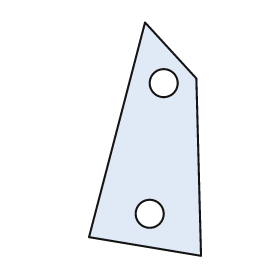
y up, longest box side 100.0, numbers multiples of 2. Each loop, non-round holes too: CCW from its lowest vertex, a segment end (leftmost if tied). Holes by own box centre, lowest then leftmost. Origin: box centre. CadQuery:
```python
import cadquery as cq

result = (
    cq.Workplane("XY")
    .moveTo(24.0, -50.0)
    .lineTo(22.0, 26.0)
    .lineTo(0.0, 50.0)
    .lineTo(-24.0, -42.0)
    .close()
    .moveTo(2.0, -32.0)
    .circle(6.0)
    .moveTo(8.0, 24.0)
    .circle(6.0)
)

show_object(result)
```